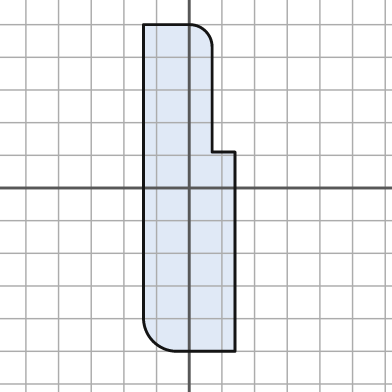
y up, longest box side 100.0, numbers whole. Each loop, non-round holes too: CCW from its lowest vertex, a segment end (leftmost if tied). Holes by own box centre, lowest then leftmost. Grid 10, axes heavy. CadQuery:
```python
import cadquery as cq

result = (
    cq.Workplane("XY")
    .moveTo(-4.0, -50.0)
    .lineTo(14.0, -50.0)
    .lineTo(14.0, 11.0)
    .lineTo(7.0, 11.0)
    .lineTo(7.0, 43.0)
    .threePointArc((5.0, 48.0), (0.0, 50.0))
    .lineTo(-14.0, 50.0)
    .lineTo(-14.0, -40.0)
    .threePointArc((-11.0, -47.0), (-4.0, -50.0))
    .close()
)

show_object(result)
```